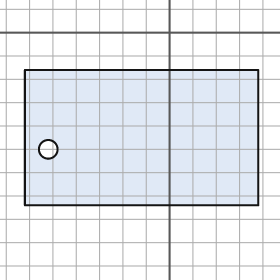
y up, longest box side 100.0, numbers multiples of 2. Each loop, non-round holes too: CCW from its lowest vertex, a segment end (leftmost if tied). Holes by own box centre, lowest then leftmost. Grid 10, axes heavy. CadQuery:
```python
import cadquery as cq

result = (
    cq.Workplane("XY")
    .moveTo(-62.0, -74.0)
    .lineTo(38.0, -74.0)
    .lineTo(38.0, -16.0)
    .lineTo(-62.0, -16.0)
    .close()
    .moveTo(-52.0, -50.0)
    .circle(4.0)
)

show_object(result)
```